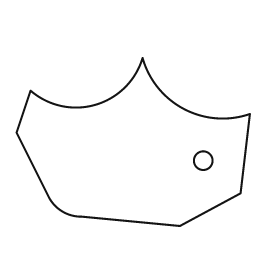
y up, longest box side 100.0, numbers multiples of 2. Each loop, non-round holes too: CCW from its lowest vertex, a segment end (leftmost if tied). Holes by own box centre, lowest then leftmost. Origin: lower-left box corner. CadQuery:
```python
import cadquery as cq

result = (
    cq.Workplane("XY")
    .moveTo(70.0, 0.0)
    .lineTo(96.0, 14.0)
    .lineTo(100.0, 48.0)
    .threePointArc((72.0, 50.0), (54.0, 72.0))
    .threePointArc((34.0, 52.0), (6.0, 58.0))
    .lineTo(0.0, 40.0)
    .lineTo(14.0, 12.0)
    .threePointArc((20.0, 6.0), (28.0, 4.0))
    .close()
    .moveTo(80.0, 28.0)
    .circle(4.0)
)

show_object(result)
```